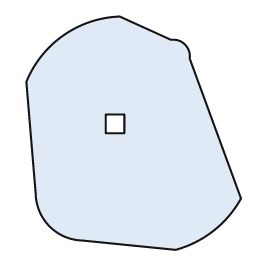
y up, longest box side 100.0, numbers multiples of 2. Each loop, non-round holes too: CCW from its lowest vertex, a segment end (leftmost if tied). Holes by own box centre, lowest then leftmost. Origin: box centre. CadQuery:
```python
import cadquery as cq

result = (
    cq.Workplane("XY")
    .moveTo(18.0, -50.0)
    .threePointArc((34.0, -42.0), (46.0, -28.0))
    .lineTo(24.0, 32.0)
    .threePointArc((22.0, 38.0), (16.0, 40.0))
    .lineTo(-6.0, 50.0)
    .threePointArc((-30.0, 42.0), (-46.0, 22.0))
    .lineTo(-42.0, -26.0)
    .threePointArc((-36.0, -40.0), (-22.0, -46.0))
    .close()
    .moveTo(-12.0, 0.0)
    .lineTo(-4.0, 0.0)
    .lineTo(-4.0, 8.0)
    .lineTo(-12.0, 8.0)
    .close()
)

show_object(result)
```